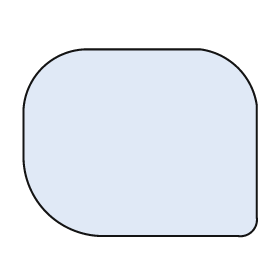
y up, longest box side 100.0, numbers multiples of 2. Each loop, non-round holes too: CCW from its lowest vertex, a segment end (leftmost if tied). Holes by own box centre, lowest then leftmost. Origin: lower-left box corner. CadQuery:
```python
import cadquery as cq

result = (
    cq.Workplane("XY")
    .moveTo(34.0, 0.0)
    .lineTo(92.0, 0.0)
    .threePointArc((98.0, 2.0), (100.0, 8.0))
    .lineTo(100.0, 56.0)
    .threePointArc((92.0, 72.0), (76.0, 80.0))
    .lineTo(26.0, 80.0)
    .threePointArc((8.0, 72.0), (0.0, 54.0))
    .lineTo(0.0, 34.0)
    .threePointArc((10.0, 10.0), (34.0, 0.0))
    .close()
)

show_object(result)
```